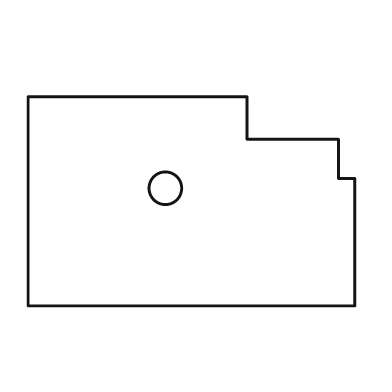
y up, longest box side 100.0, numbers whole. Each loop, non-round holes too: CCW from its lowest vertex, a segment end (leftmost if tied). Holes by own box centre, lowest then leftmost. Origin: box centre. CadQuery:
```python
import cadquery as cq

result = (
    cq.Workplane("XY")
    .moveTo(-50.0, -32.0)
    .lineTo(50.0, -32.0)
    .lineTo(50.0, 7.0)
    .lineTo(45.0, 7.0)
    .lineTo(45.0, 19.0)
    .lineTo(17.0, 19.0)
    .lineTo(17.0, 32.0)
    .lineTo(-50.0, 32.0)
    .close()
    .moveTo(-8.0, 4.0)
    .circle(5.0)
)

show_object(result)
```